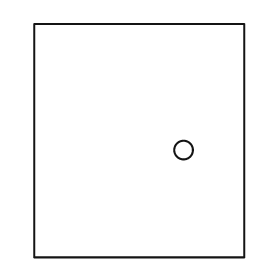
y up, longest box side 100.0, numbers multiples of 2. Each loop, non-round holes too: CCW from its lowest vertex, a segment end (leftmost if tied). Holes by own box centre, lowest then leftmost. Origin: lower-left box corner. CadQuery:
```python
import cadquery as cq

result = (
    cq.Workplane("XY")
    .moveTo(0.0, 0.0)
    .lineTo(90.0, 0.0)
    .lineTo(90.0, 100.0)
    .lineTo(0.0, 100.0)
    .close()
    .moveTo(64.0, 46.0)
    .circle(4.0)
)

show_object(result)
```